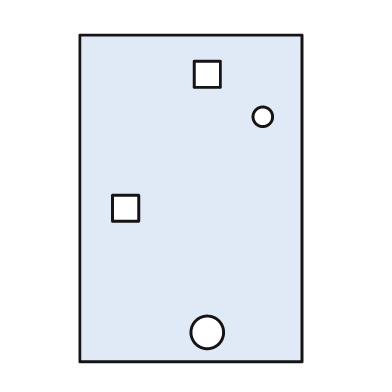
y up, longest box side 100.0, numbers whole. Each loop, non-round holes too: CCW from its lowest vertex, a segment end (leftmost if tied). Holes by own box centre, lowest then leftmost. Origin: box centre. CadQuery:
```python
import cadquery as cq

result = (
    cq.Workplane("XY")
    .moveTo(-34.0, -50.0)
    .lineTo(34.0, -50.0)
    .lineTo(34.0, 50.0)
    .lineTo(-34.0, 50.0)
    .close()
    .moveTo(5.0, -41.0)
    .circle(5.0)
    .moveTo(-24.0, -7.0)
    .lineTo(-16.0, -7.0)
    .lineTo(-16.0, 1.0)
    .lineTo(-24.0, 1.0)
    .close()
    .moveTo(22.0, 25.0)
    .circle(3.0)
    .moveTo(1.0, 34.0)
    .lineTo(9.0, 34.0)
    .lineTo(9.0, 42.0)
    .lineTo(1.0, 42.0)
    .close()
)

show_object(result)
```